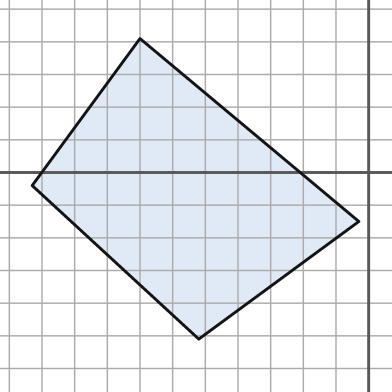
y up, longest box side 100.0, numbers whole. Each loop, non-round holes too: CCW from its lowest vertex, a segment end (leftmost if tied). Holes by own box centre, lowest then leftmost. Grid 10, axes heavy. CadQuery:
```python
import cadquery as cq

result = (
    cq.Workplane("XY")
    .moveTo(-52.0, -51.0)
    .lineTo(-3.0, -15.0)
    .lineTo(-70.0, 41.0)
    .lineTo(-103.0, -4.0)
    .close()
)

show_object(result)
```